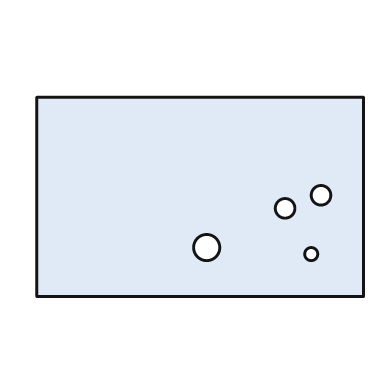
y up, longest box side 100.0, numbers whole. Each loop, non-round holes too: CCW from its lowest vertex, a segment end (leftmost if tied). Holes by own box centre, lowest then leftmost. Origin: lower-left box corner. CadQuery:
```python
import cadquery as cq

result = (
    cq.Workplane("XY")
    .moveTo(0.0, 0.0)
    .lineTo(100.0, 0.0)
    .lineTo(100.0, 61.0)
    .lineTo(0.0, 61.0)
    .close()
    .moveTo(84.0, 13.0)
    .circle(2.0)
    .moveTo(52.0, 15.0)
    .circle(4.0)
    .moveTo(76.0, 27.0)
    .circle(3.0)
    .moveTo(87.0, 31.0)
    .circle(3.0)
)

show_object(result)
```